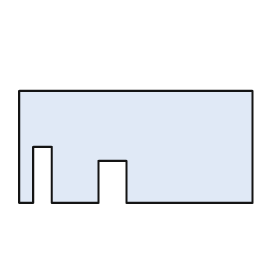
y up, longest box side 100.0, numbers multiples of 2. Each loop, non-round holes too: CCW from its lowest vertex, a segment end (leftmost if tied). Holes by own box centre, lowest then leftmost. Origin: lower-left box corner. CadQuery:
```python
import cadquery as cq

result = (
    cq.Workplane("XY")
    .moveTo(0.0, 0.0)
    .lineTo(6.0, 0.0)
    .lineTo(6.0, 24.0)
    .lineTo(14.0, 24.0)
    .lineTo(14.0, 0.0)
    .lineTo(34.0, 0.0)
    .lineTo(34.0, 18.0)
    .lineTo(46.0, 18.0)
    .lineTo(46.0, 0.0)
    .lineTo(100.0, 0.0)
    .lineTo(100.0, 48.0)
    .lineTo(0.0, 48.0)
    .close()
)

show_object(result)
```